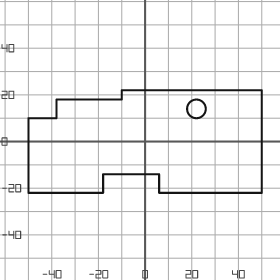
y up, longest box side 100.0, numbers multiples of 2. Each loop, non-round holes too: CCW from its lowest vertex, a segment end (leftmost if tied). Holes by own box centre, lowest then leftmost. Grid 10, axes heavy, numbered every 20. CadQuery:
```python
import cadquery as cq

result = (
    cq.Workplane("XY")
    .moveTo(-50.0, -22.0)
    .lineTo(-18.0, -22.0)
    .lineTo(-18.0, -14.0)
    .lineTo(6.0, -14.0)
    .lineTo(6.0, -22.0)
    .lineTo(50.0, -22.0)
    .lineTo(50.0, 22.0)
    .lineTo(-10.0, 22.0)
    .lineTo(-10.0, 18.0)
    .lineTo(-38.0, 18.0)
    .lineTo(-38.0, 10.0)
    .lineTo(-50.0, 10.0)
    .close()
    .moveTo(22.0, 14.0)
    .circle(4.0)
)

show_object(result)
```